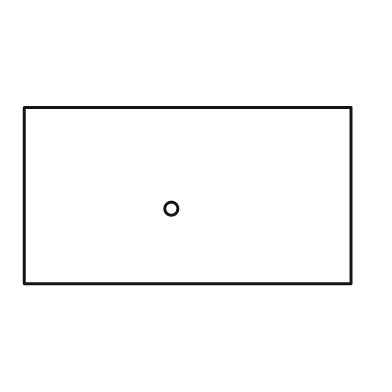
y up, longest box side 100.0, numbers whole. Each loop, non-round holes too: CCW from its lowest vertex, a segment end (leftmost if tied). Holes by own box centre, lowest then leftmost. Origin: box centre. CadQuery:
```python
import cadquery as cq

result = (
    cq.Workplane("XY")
    .moveTo(-50.0, -27.0)
    .lineTo(50.0, -27.0)
    .lineTo(50.0, 27.0)
    .lineTo(-50.0, 27.0)
    .close()
    .moveTo(-5.0, -4.0)
    .circle(2.0)
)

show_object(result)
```